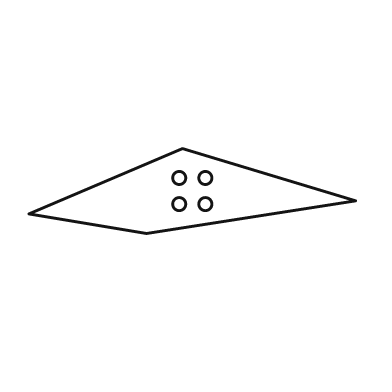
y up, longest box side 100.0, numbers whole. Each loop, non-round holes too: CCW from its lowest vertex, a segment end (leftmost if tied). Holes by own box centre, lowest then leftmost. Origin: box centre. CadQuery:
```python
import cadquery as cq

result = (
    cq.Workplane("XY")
    .moveTo(-14.0, -13.0)
    .lineTo(50.0, -3.0)
    .lineTo(-3.0, 13.0)
    .lineTo(-50.0, -7.0)
    .close()
    .moveTo(-4.0, -4.0)
    .circle(2.0)
    .moveTo(4.0, -4.0)
    .circle(2.0)
    .moveTo(-4.0, 4.0)
    .circle(2.0)
    .moveTo(4.0, 4.0)
    .circle(2.0)
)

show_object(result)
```